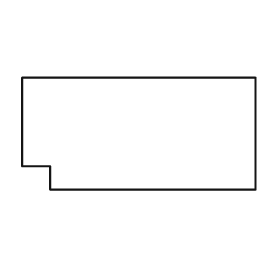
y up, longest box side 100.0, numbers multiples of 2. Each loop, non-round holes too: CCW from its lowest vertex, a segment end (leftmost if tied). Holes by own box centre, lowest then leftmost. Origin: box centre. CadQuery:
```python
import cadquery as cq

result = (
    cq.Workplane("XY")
    .moveTo(-38.0, -24.0)
    .lineTo(50.0, -24.0)
    .lineTo(50.0, 24.0)
    .lineTo(-50.0, 24.0)
    .lineTo(-50.0, -14.0)
    .lineTo(-38.0, -14.0)
    .close()
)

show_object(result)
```